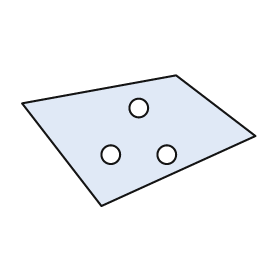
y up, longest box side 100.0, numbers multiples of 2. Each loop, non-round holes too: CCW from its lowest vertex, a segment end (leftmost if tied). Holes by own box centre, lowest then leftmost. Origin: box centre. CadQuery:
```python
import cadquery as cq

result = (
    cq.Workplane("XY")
    .moveTo(-16.0, -28.0)
    .lineTo(50.0, 2.0)
    .lineTo(16.0, 28.0)
    .lineTo(-50.0, 16.0)
    .close()
    .moveTo(-12.0, -6.0)
    .circle(4.0)
    .moveTo(12.0, -6.0)
    .circle(4.0)
    .moveTo(0.0, 14.0)
    .circle(4.0)
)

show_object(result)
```